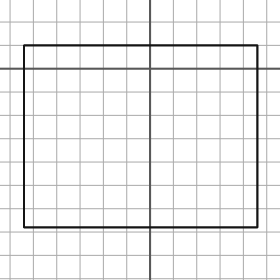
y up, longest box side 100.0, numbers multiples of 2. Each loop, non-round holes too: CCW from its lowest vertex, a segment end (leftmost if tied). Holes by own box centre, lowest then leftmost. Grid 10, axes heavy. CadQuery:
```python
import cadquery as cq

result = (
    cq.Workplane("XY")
    .moveTo(-54.0, -68.0)
    .lineTo(46.0, -68.0)
    .lineTo(46.0, 10.0)
    .lineTo(-54.0, 10.0)
    .close()
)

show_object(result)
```